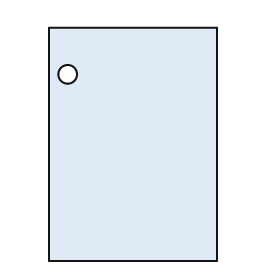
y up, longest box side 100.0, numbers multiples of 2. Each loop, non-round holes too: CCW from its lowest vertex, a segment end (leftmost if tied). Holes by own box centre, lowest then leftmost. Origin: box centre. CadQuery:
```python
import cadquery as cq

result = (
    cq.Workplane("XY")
    .moveTo(-36.0, -50.0)
    .lineTo(36.0, -50.0)
    .lineTo(36.0, 50.0)
    .lineTo(-36.0, 50.0)
    .close()
    .moveTo(-28.0, 30.0)
    .circle(4.0)
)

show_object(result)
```